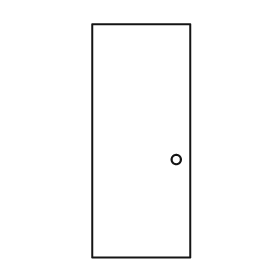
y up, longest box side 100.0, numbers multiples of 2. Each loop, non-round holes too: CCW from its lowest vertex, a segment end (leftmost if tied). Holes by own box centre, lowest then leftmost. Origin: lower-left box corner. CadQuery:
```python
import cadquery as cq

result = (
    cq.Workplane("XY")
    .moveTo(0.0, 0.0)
    .lineTo(42.0, 0.0)
    .lineTo(42.0, 100.0)
    .lineTo(0.0, 100.0)
    .close()
    .moveTo(36.0, 42.0)
    .circle(2.0)
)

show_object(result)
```